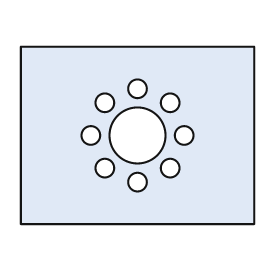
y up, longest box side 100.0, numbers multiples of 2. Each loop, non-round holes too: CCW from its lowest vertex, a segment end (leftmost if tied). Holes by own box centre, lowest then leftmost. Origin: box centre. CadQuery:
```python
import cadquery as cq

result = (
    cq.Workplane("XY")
    .moveTo(-50.0, -38.0)
    .lineTo(50.0, -38.0)
    .lineTo(50.0, 38.0)
    .lineTo(-50.0, 38.0)
    .close()
    .moveTo(0.0, -20.0)
    .circle(4.0)
    .moveTo(-14.0, -14.0)
    .circle(4.0)
    .moveTo(14.0, -14.0)
    .circle(4.0)
    .moveTo(-20.0, 0.0)
    .circle(4.0)
    .moveTo(0.0, 0.0)
    .circle(12.0)
    .moveTo(20.0, 0.0)
    .circle(4.0)
    .moveTo(-14.0, 14.0)
    .circle(4.0)
    .moveTo(14.0, 14.0)
    .circle(4.0)
    .moveTo(0.0, 20.0)
    .circle(4.0)
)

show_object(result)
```